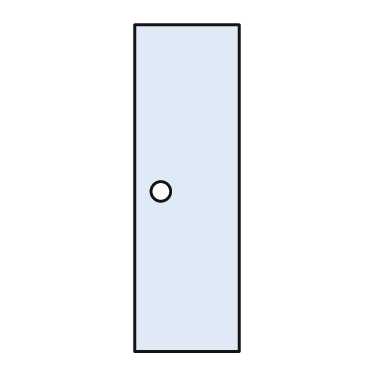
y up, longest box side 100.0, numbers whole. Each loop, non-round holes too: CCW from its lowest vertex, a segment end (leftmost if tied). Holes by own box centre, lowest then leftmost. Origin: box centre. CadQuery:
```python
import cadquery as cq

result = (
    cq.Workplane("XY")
    .moveTo(-16.0, -50.0)
    .lineTo(16.0, -50.0)
    .lineTo(16.0, 50.0)
    .lineTo(-16.0, 50.0)
    .close()
    .moveTo(-8.0, -1.0)
    .circle(3.0)
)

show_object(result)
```